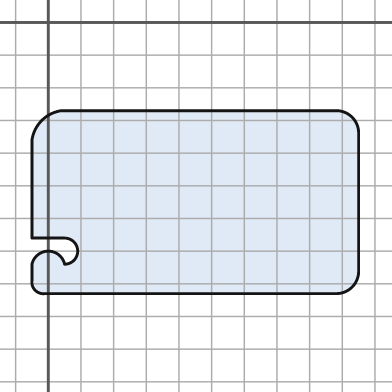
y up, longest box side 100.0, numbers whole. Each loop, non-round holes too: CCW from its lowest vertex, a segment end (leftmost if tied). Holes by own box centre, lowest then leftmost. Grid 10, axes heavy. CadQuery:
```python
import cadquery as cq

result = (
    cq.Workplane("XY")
    .moveTo(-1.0, -83.0)
    .lineTo(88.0, -83.0)
    .threePointArc((93.0, -81.0), (95.0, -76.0))
    .lineTo(95.0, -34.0)
    .threePointArc((93.0, -29.0), (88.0, -27.0))
    .lineTo(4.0, -27.0)
    .threePointArc((-2.0, -30.0), (-5.0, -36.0))
    .lineTo(-5.0, -66.0)
    .lineTo(5.0, -66.0)
    .threePointArc((9.0, -70.0), (5.0, -74.0))
    .threePointArc((0.0, -70.0), (-5.0, -74.0))
    .lineTo(-5.0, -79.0)
    .threePointArc((-4.0, -82.0), (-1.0, -83.0))
    .close()
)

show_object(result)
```